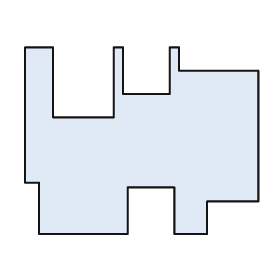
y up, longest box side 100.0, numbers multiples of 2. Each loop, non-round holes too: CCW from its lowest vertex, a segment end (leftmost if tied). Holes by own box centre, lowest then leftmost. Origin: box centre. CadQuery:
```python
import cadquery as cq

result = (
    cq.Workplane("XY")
    .moveTo(-44.0, -40.0)
    .lineTo(-6.0, -40.0)
    .lineTo(-6.0, -20.0)
    .lineTo(14.0, -20.0)
    .lineTo(14.0, -40.0)
    .lineTo(28.0, -40.0)
    .lineTo(28.0, -26.0)
    .lineTo(50.0, -26.0)
    .lineTo(50.0, 30.0)
    .lineTo(16.0, 30.0)
    .lineTo(16.0, 40.0)
    .lineTo(12.0, 40.0)
    .lineTo(12.0, 20.0)
    .lineTo(-8.0, 20.0)
    .lineTo(-8.0, 40.0)
    .lineTo(-12.0, 40.0)
    .lineTo(-12.0, 10.0)
    .lineTo(-38.0, 10.0)
    .lineTo(-38.0, 40.0)
    .lineTo(-50.0, 40.0)
    .lineTo(-50.0, -18.0)
    .lineTo(-44.0, -18.0)
    .close()
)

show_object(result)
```